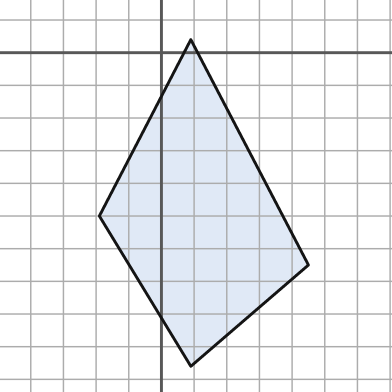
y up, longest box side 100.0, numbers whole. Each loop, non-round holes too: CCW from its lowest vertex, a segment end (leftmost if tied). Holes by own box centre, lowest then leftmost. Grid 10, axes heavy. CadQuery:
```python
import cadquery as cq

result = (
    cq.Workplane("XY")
    .moveTo(9.0, -96.0)
    .lineTo(45.0, -65.0)
    .lineTo(9.0, 4.0)
    .lineTo(-19.0, -50.0)
    .close()
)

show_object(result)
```